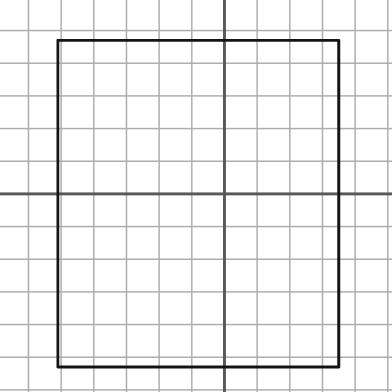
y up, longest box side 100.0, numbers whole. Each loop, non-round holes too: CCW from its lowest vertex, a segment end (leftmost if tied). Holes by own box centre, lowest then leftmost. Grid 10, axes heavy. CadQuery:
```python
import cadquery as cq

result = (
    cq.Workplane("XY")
    .moveTo(-51.0, -53.0)
    .lineTo(35.0, -53.0)
    .lineTo(35.0, 47.0)
    .lineTo(-51.0, 47.0)
    .close()
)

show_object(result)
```